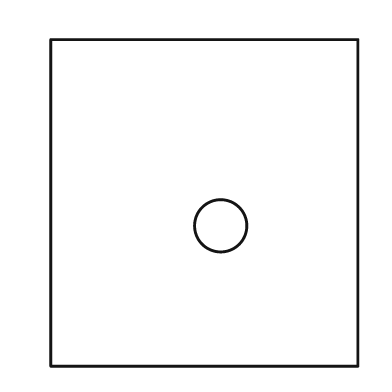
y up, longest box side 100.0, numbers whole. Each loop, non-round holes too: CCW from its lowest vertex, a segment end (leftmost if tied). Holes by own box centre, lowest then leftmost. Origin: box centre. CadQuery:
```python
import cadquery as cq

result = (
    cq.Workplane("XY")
    .moveTo(-47.0, -50.0)
    .lineTo(47.0, -50.0)
    .lineTo(47.0, 50.0)
    .lineTo(-47.0, 50.0)
    .close()
    .moveTo(5.0, -7.0)
    .circle(8.0)
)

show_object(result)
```